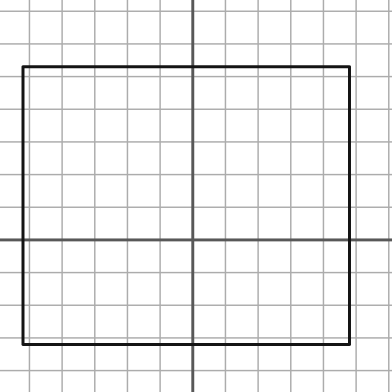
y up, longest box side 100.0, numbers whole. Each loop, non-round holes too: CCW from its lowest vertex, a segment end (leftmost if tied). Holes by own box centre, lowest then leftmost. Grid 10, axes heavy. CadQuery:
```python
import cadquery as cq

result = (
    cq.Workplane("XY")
    .moveTo(-52.0, -32.0)
    .lineTo(48.0, -32.0)
    .lineTo(48.0, 53.0)
    .lineTo(-52.0, 53.0)
    .close()
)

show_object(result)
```